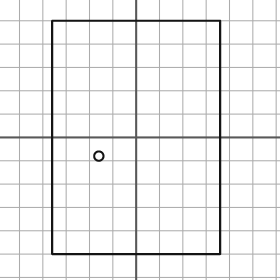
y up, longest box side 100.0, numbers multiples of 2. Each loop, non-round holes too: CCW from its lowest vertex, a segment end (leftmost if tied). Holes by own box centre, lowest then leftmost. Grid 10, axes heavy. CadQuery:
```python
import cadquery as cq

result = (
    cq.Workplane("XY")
    .moveTo(-36.0, -50.0)
    .lineTo(36.0, -50.0)
    .lineTo(36.0, 50.0)
    .lineTo(-36.0, 50.0)
    .close()
    .moveTo(-16.0, -8.0)
    .circle(2.0)
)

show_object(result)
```